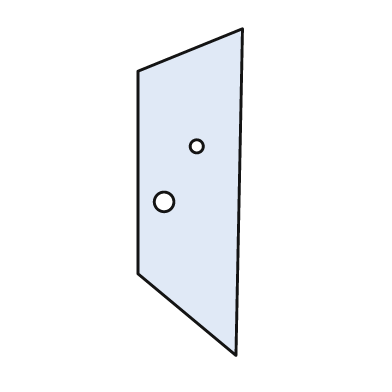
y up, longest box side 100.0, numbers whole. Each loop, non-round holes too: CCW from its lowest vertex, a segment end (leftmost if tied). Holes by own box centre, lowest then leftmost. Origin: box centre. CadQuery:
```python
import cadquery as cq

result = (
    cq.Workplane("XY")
    .moveTo(14.0, -50.0)
    .lineTo(16.0, 50.0)
    .lineTo(-16.0, 37.0)
    .lineTo(-16.0, -25.0)
    .close()
    .moveTo(-8.0, -3.0)
    .circle(3.0)
    .moveTo(2.0, 14.0)
    .circle(2.0)
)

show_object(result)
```